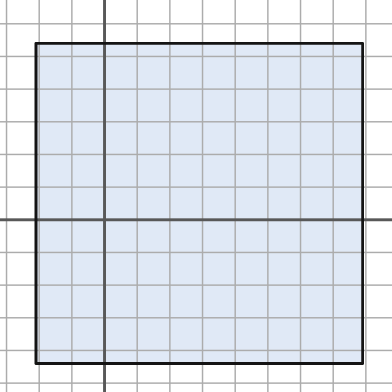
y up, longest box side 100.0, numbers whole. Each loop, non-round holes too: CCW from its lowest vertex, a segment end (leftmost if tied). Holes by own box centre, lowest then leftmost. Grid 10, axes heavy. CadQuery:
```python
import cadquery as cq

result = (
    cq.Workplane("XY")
    .moveTo(-21.0, -44.0)
    .lineTo(79.0, -44.0)
    .lineTo(79.0, 54.0)
    .lineTo(-21.0, 54.0)
    .close()
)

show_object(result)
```